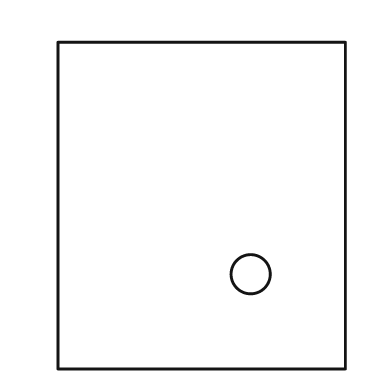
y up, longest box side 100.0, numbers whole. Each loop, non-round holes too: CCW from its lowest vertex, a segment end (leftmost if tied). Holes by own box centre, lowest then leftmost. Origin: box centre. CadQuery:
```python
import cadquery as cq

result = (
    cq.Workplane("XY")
    .moveTo(-44.0, -50.0)
    .lineTo(44.0, -50.0)
    .lineTo(44.0, 50.0)
    .lineTo(-44.0, 50.0)
    .close()
    .moveTo(15.0, -21.0)
    .circle(6.0)
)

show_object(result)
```